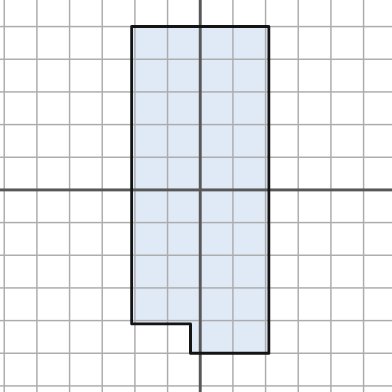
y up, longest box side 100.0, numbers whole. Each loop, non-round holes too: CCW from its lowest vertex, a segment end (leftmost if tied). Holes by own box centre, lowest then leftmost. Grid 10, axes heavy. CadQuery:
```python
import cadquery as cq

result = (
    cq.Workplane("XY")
    .moveTo(-3.0, -50.0)
    .lineTo(21.0, -50.0)
    .lineTo(21.0, 50.0)
    .lineTo(-21.0, 50.0)
    .lineTo(-21.0, -41.0)
    .lineTo(-3.0, -41.0)
    .close()
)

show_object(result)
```